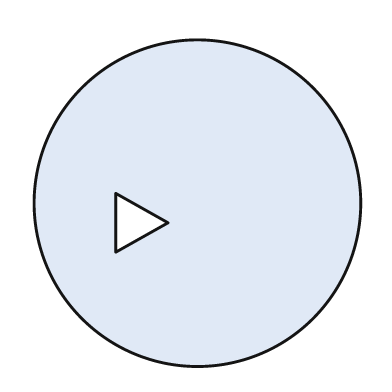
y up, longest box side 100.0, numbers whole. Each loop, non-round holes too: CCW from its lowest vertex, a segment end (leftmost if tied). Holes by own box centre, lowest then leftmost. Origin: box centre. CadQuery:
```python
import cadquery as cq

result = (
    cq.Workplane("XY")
    .moveTo(0.0, 0.0)
    .circle(50.0)
    .moveTo(-25.0, -15.0)
    .lineTo(-9.0, -6.0)
    .lineTo(-25.0, 3.0)
    .close()
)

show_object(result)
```